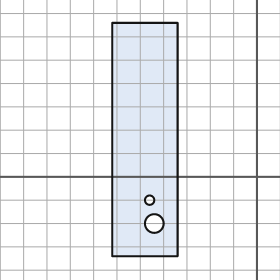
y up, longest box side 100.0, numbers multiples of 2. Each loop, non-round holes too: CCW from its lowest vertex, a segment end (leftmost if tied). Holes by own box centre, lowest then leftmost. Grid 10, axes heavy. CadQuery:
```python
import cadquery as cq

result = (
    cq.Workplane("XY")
    .moveTo(-62.0, -34.0)
    .lineTo(-34.0, -34.0)
    .lineTo(-34.0, 66.0)
    .lineTo(-62.0, 66.0)
    .close()
    .moveTo(-44.0, -20.0)
    .circle(4.0)
    .moveTo(-46.0, -10.0)
    .circle(2.0)
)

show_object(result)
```